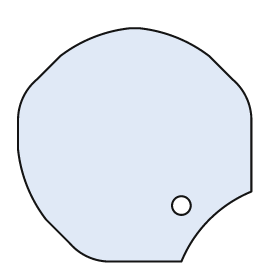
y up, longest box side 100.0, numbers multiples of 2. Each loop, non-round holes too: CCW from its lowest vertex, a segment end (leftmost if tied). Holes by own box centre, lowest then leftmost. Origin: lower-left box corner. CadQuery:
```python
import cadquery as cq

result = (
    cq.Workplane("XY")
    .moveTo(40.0, 0.0)
    .lineTo(70.0, 0.0)
    .threePointArc((82.0, 18.0), (100.0, 30.0))
    .lineTo(100.0, 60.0)
    .threePointArc((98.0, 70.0), (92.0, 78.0))
    .lineTo(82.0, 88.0)
    .threePointArc((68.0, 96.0), (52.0, 100.0))
    .lineTo(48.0, 100.0)
    .threePointArc((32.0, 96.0), (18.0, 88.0))
    .lineTo(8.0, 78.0)
    .threePointArc((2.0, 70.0), (0.0, 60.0))
    .lineTo(0.0, 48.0)
    .threePointArc((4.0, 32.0), (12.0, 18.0))
    .lineTo(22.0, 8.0)
    .threePointArc((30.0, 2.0), (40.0, 0.0))
    .close()
    .moveTo(70.0, 24.0)
    .circle(4.0)
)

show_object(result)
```